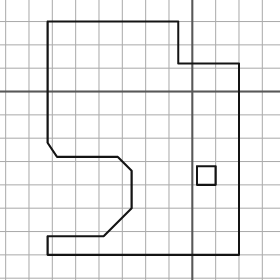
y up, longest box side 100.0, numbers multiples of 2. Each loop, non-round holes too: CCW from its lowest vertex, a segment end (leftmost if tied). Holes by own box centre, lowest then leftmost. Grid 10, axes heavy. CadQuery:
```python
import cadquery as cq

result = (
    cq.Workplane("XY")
    .moveTo(-62.0, -70.0)
    .lineTo(20.0, -70.0)
    .lineTo(20.0, 12.0)
    .lineTo(-6.0, 12.0)
    .lineTo(-6.0, 30.0)
    .lineTo(-62.0, 30.0)
    .lineTo(-62.0, -22.0)
    .lineTo(-58.0, -28.0)
    .lineTo(-32.0, -28.0)
    .lineTo(-26.0, -34.0)
    .lineTo(-26.0, -50.0)
    .lineTo(-38.0, -62.0)
    .lineTo(-62.0, -62.0)
    .close()
    .moveTo(2.0, -40.0)
    .lineTo(10.0, -40.0)
    .lineTo(10.0, -32.0)
    .lineTo(2.0, -32.0)
    .close()
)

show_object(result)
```